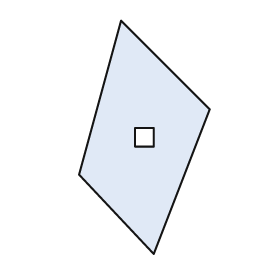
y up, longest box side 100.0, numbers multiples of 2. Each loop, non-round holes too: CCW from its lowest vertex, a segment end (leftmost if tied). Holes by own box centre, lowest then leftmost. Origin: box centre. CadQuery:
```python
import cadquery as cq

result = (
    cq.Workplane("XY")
    .moveTo(4.0, -50.0)
    .lineTo(28.0, 12.0)
    .lineTo(-10.0, 50.0)
    .lineTo(-28.0, -16.0)
    .close()
    .moveTo(-4.0, -4.0)
    .lineTo(4.0, -4.0)
    .lineTo(4.0, 4.0)
    .lineTo(-4.0, 4.0)
    .close()
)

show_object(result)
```